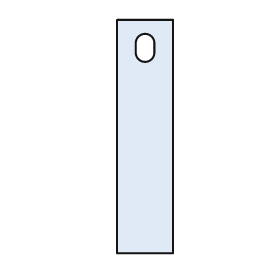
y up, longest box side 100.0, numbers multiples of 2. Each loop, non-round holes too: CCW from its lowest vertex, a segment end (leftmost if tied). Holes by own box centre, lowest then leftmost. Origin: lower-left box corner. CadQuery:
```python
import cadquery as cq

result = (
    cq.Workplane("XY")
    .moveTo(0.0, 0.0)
    .lineTo(24.0, 0.0)
    .lineTo(24.0, 100.0)
    .lineTo(0.0, 100.0)
    .close()
    .moveTo(8.0, 86.0)
    .threePointArc((12.0, 82.0), (16.0, 86.0))
    .lineTo(16.0, 90.0)
    .threePointArc((12.0, 94.0), (8.0, 90.0))
    .close()
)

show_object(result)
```